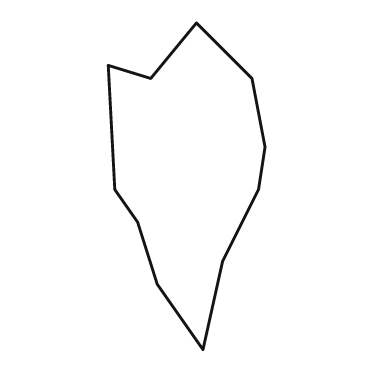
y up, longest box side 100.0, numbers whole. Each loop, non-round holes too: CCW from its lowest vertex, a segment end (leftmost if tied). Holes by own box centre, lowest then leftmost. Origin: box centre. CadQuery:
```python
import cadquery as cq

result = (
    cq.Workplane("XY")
    .moveTo(5.0, -50.0)
    .lineTo(11.0, -23.0)
    .lineTo(22.0, -1.0)
    .lineTo(24.0, 12.0)
    .lineTo(20.0, 33.0)
    .lineTo(3.0, 50.0)
    .lineTo(-11.0, 33.0)
    .lineTo(-24.0, 37.0)
    .lineTo(-22.0, -1.0)
    .lineTo(-15.0, -11.0)
    .lineTo(-9.0, -30.0)
    .close()
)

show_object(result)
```